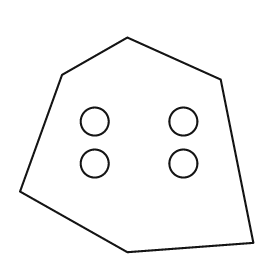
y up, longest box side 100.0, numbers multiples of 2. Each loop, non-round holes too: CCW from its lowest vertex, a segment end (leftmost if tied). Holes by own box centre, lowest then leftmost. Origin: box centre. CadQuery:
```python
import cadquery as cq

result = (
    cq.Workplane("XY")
    .moveTo(-4.0, -46.0)
    .lineTo(50.0, -42.0)
    .lineTo(36.0, 28.0)
    .lineTo(-4.0, 46.0)
    .lineTo(-32.0, 30.0)
    .lineTo(-50.0, -20.0)
    .close()
    .moveTo(-18.0, -8.0)
    .circle(6.0)
    .moveTo(20.0, -8.0)
    .circle(6.0)
    .moveTo(-18.0, 10.0)
    .circle(6.0)
    .moveTo(20.0, 10.0)
    .circle(6.0)
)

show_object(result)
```